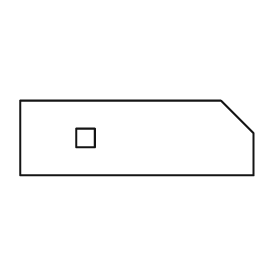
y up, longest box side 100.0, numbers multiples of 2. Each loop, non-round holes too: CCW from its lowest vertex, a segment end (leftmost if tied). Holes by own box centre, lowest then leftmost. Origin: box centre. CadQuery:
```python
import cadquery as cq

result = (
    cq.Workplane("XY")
    .moveTo(-50.0, -16.0)
    .lineTo(50.0, -16.0)
    .lineTo(50.0, 2.0)
    .lineTo(36.0, 16.0)
    .lineTo(-50.0, 16.0)
    .close()
    .moveTo(-26.0, -4.0)
    .lineTo(-18.0, -4.0)
    .lineTo(-18.0, 4.0)
    .lineTo(-26.0, 4.0)
    .close()
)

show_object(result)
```